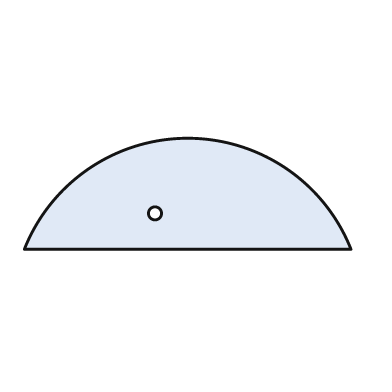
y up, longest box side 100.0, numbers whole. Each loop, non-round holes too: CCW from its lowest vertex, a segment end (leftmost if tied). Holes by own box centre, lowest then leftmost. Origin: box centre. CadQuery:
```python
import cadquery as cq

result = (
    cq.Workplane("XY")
    .moveTo(-50.0, -17.0)
    .lineTo(50.0, -17.0)
    .threePointArc((0.0, 17.0), (-50.0, -17.0))
    .close()
    .moveTo(-10.0, -6.0)
    .circle(2.0)
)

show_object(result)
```